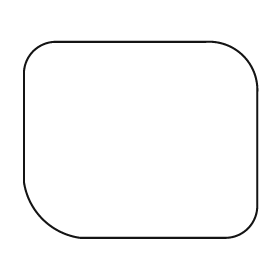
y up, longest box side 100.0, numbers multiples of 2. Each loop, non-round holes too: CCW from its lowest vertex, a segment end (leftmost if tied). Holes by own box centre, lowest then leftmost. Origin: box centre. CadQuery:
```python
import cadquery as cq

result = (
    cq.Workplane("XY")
    .moveTo(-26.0, -42.0)
    .lineTo(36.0, -42.0)
    .threePointArc((46.0, -38.0), (50.0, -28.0))
    .lineTo(50.0, 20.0)
    .threePointArc((44.0, 36.0), (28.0, 42.0))
    .lineTo(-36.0, 42.0)
    .threePointArc((-46.0, 38.0), (-50.0, 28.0))
    .lineTo(-50.0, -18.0)
    .threePointArc((-42.0, -34.0), (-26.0, -42.0))
    .close()
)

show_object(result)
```